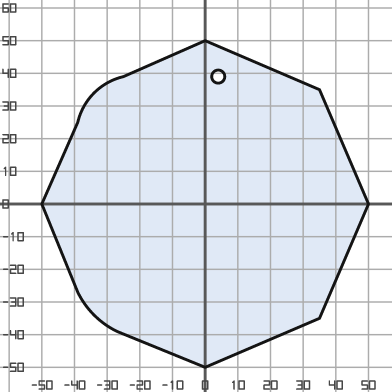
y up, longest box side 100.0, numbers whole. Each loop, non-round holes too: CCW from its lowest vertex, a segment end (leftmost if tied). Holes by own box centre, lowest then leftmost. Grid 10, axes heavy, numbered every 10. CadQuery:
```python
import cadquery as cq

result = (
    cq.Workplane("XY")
    .moveTo(0.0, -50.0)
    .lineTo(35.0, -35.0)
    .lineTo(50.0, 0.0)
    .lineTo(35.0, 35.0)
    .lineTo(0.0, 50.0)
    .lineTo(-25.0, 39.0)
    .threePointArc((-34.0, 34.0), (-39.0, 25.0))
    .lineTo(-50.0, 0.0)
    .lineTo(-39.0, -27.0)
    .threePointArc((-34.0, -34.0), (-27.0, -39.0))
    .close()
    .moveTo(4.0, 39.0)
    .circle(2.0)
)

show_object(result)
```